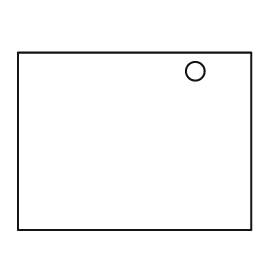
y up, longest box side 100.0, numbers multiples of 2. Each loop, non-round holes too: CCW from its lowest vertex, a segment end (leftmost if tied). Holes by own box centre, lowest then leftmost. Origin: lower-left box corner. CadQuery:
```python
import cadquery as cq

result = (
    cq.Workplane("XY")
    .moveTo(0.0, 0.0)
    .lineTo(100.0, 0.0)
    .lineTo(100.0, 76.0)
    .lineTo(0.0, 76.0)
    .close()
    .moveTo(76.0, 68.0)
    .circle(4.0)
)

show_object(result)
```